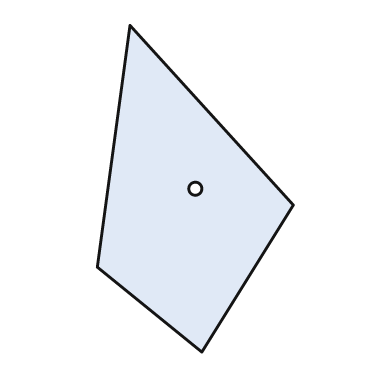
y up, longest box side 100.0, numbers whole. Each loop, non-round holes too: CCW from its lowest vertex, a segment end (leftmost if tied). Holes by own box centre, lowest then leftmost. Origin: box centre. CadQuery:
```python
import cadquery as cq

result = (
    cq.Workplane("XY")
    .moveTo(2.0, -50.0)
    .lineTo(30.0, -5.0)
    .lineTo(-20.0, 50.0)
    .lineTo(-30.0, -24.0)
    .close()
    .moveTo(0.0, 0.0)
    .circle(2.0)
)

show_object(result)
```